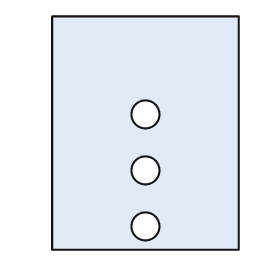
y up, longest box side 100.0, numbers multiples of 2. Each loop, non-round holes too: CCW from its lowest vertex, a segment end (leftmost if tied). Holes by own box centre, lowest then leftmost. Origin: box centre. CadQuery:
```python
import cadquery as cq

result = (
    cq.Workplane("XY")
    .moveTo(-40.0, -50.0)
    .lineTo(40.0, -50.0)
    .lineTo(40.0, 50.0)
    .lineTo(-40.0, 50.0)
    .close()
    .moveTo(0.0, -40.0)
    .circle(6.0)
    .moveTo(0.0, -16.0)
    .circle(6.0)
    .moveTo(0.0, 8.0)
    .circle(6.0)
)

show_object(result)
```